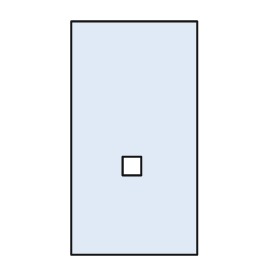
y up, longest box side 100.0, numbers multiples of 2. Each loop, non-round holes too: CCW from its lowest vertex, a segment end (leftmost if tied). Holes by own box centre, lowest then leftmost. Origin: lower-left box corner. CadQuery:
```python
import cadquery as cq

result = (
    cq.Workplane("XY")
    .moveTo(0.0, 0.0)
    .lineTo(54.0, 0.0)
    .lineTo(54.0, 100.0)
    .lineTo(0.0, 100.0)
    .close()
    .moveTo(22.0, 34.0)
    .lineTo(30.0, 34.0)
    .lineTo(30.0, 42.0)
    .lineTo(22.0, 42.0)
    .close()
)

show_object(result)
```